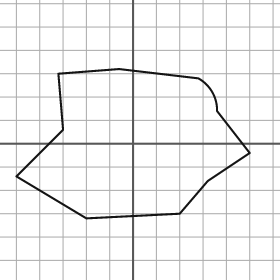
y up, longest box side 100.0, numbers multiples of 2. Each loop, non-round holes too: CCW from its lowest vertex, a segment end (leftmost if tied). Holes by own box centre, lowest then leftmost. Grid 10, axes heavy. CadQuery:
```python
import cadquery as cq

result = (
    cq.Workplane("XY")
    .moveTo(-20.0, -32.0)
    .lineTo(20.0, -30.0)
    .lineTo(32.0, -16.0)
    .lineTo(50.0, -4.0)
    .lineTo(36.0, 14.0)
    .threePointArc((34.0, 22.0), (28.0, 28.0))
    .lineTo(-6.0, 32.0)
    .lineTo(-32.0, 30.0)
    .lineTo(-30.0, 6.0)
    .lineTo(-50.0, -14.0)
    .close()
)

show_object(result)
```